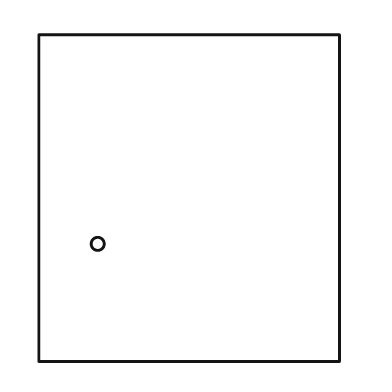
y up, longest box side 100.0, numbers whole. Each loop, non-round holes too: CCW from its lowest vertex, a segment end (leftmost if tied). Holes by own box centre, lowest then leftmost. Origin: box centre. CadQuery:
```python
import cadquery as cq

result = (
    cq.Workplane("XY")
    .moveTo(-46.0, -50.0)
    .lineTo(46.0, -50.0)
    .lineTo(46.0, 50.0)
    .lineTo(-46.0, 50.0)
    .close()
    .moveTo(-28.0, -14.0)
    .circle(2.0)
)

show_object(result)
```